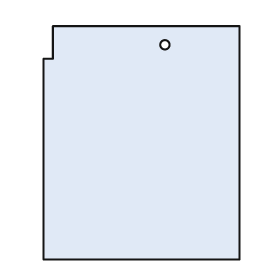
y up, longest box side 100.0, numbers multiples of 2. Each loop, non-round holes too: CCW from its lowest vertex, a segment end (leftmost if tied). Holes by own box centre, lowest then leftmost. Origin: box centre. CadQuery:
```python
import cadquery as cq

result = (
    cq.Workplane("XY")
    .moveTo(-42.0, -50.0)
    .lineTo(42.0, -50.0)
    .lineTo(42.0, 50.0)
    .lineTo(-38.0, 50.0)
    .lineTo(-38.0, 36.0)
    .lineTo(-42.0, 36.0)
    .close()
    .moveTo(10.0, 42.0)
    .circle(2.0)
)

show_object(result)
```